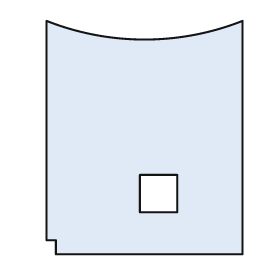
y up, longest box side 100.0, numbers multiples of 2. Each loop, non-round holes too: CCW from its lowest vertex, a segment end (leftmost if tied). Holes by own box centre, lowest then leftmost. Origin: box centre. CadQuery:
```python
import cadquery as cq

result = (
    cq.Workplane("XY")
    .moveTo(-38.0, -50.0)
    .lineTo(42.0, -50.0)
    .lineTo(42.0, 50.0)
    .threePointArc((0.0, 42.0), (-42.0, 50.0))
    .lineTo(-42.0, -44.0)
    .lineTo(-38.0, -44.0)
    .close()
    .moveTo(-2.0, -32.0)
    .lineTo(14.0, -32.0)
    .lineTo(14.0, -16.0)
    .lineTo(-2.0, -16.0)
    .close()
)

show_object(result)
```